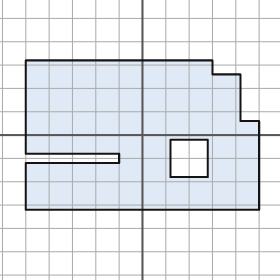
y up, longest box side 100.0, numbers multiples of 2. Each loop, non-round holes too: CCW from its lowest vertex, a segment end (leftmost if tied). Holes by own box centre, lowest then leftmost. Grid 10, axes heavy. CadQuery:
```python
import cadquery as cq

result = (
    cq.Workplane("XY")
    .moveTo(-50.0, -32.0)
    .lineTo(50.0, -32.0)
    .lineTo(50.0, 6.0)
    .lineTo(42.0, 6.0)
    .lineTo(42.0, 26.0)
    .lineTo(30.0, 26.0)
    .lineTo(30.0, 32.0)
    .lineTo(-50.0, 32.0)
    .lineTo(-50.0, -8.0)
    .lineTo(-10.0, -8.0)
    .lineTo(-10.0, -12.0)
    .lineTo(-50.0, -12.0)
    .close()
    .moveTo(12.0, -18.0)
    .lineTo(28.0, -18.0)
    .lineTo(28.0, -2.0)
    .lineTo(12.0, -2.0)
    .close()
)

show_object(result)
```